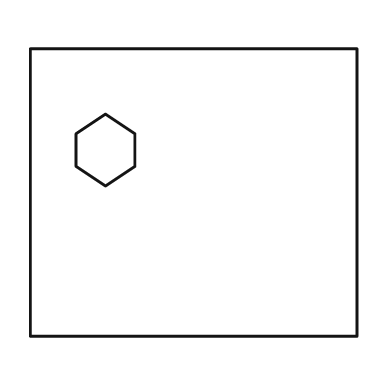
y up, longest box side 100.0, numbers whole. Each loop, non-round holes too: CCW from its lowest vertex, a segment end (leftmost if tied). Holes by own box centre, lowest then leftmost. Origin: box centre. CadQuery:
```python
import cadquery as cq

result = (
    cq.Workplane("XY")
    .moveTo(-50.0, -44.0)
    .lineTo(50.0, -44.0)
    .lineTo(50.0, 44.0)
    .lineTo(-50.0, 44.0)
    .close()
    .moveTo(-27.0, 2.0)
    .lineTo(-18.0, 8.0)
    .lineTo(-18.0, 18.0)
    .lineTo(-27.0, 24.0)
    .lineTo(-36.0, 18.0)
    .lineTo(-36.0, 8.0)
    .close()
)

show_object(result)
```